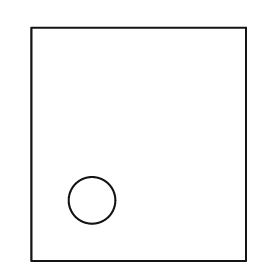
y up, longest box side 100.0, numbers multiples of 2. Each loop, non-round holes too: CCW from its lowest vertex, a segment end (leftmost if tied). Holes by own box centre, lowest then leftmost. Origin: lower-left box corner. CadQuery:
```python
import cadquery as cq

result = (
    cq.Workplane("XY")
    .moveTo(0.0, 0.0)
    .lineTo(92.0, 0.0)
    .lineTo(92.0, 100.0)
    .lineTo(0.0, 100.0)
    .close()
    .moveTo(26.0, 26.0)
    .circle(10.0)
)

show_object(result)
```